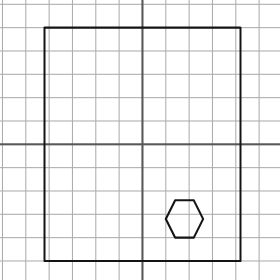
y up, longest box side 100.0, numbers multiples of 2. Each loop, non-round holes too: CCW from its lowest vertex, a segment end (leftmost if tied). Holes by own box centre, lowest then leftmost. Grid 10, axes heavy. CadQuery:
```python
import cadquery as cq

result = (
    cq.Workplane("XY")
    .moveTo(-42.0, -50.0)
    .lineTo(42.0, -50.0)
    .lineTo(42.0, 50.0)
    .lineTo(-42.0, 50.0)
    .close()
    .moveTo(14.0, -40.0)
    .lineTo(22.0, -40.0)
    .lineTo(26.0, -32.0)
    .lineTo(22.0, -24.0)
    .lineTo(14.0, -24.0)
    .lineTo(10.0, -32.0)
    .close()
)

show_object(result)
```